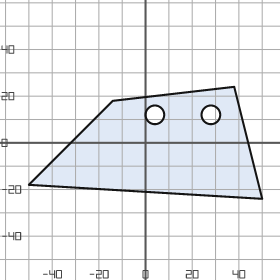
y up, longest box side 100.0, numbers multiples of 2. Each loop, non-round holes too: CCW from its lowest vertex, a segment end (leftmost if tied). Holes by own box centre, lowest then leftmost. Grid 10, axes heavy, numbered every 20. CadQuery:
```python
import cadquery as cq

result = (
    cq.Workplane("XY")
    .moveTo(50.0, -24.0)
    .lineTo(38.0, 24.0)
    .lineTo(-14.0, 18.0)
    .lineTo(-50.0, -18.0)
    .close()
    .moveTo(4.0, 12.0)
    .circle(4.0)
    .moveTo(28.0, 12.0)
    .circle(4.0)
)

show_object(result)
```